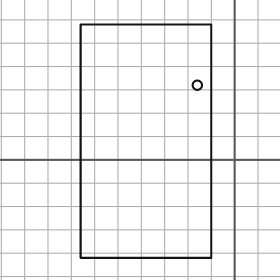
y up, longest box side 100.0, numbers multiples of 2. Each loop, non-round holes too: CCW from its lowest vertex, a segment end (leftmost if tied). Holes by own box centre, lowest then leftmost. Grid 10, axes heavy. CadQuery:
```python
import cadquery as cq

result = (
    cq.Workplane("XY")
    .moveTo(-66.0, -42.0)
    .lineTo(-10.0, -42.0)
    .lineTo(-10.0, 58.0)
    .lineTo(-66.0, 58.0)
    .close()
    .moveTo(-16.0, 32.0)
    .circle(2.0)
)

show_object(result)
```